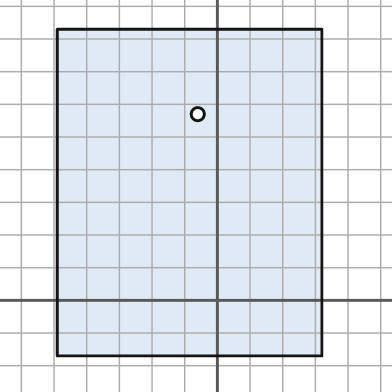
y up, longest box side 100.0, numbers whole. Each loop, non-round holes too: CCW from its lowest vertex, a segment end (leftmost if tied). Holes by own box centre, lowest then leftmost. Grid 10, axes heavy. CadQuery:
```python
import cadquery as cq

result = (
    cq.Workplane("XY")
    .moveTo(-49.0, -17.0)
    .lineTo(32.0, -17.0)
    .lineTo(32.0, 83.0)
    .lineTo(-49.0, 83.0)
    .close()
    .moveTo(-6.0, 57.0)
    .circle(2.0)
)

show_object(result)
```